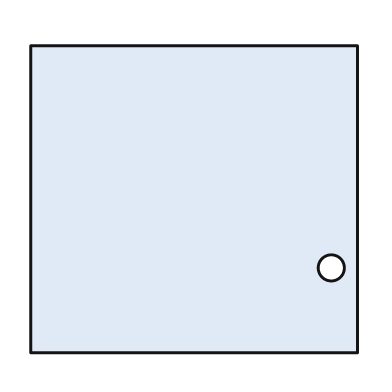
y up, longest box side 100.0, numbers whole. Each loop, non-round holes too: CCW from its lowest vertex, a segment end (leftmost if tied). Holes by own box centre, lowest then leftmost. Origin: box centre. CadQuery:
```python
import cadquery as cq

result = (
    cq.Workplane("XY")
    .moveTo(-50.0, -47.0)
    .lineTo(50.0, -47.0)
    .lineTo(50.0, 47.0)
    .lineTo(-50.0, 47.0)
    .close()
    .moveTo(42.0, -21.0)
    .circle(4.0)
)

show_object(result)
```